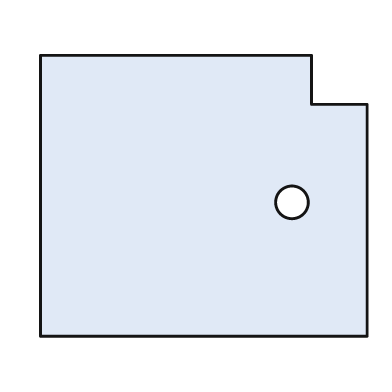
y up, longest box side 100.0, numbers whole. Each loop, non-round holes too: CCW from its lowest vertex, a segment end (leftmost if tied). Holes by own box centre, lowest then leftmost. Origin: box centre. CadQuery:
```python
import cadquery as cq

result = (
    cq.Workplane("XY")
    .moveTo(-50.0, -43.0)
    .lineTo(50.0, -43.0)
    .lineTo(50.0, 28.0)
    .lineTo(33.0, 28.0)
    .lineTo(33.0, 43.0)
    .lineTo(-50.0, 43.0)
    .close()
    .moveTo(27.0, -2.0)
    .circle(5.0)
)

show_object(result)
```